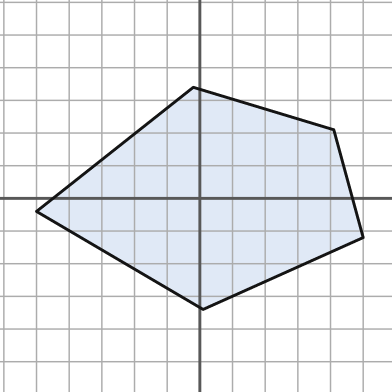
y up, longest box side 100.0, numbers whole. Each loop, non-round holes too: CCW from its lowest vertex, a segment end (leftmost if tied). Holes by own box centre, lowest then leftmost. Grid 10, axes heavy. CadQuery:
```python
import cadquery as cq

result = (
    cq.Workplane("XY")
    .moveTo(1.0, -34.0)
    .lineTo(50.0, -12.0)
    .lineTo(41.0, 21.0)
    .lineTo(-2.0, 34.0)
    .lineTo(-50.0, -4.0)
    .close()
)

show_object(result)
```